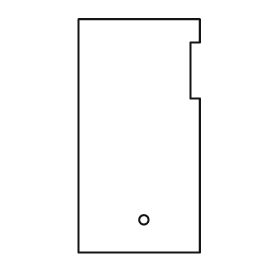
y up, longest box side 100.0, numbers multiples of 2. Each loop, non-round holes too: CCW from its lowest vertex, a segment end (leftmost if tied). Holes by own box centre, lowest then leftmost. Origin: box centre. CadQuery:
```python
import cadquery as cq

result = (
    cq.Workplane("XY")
    .moveTo(-26.0, -50.0)
    .lineTo(26.0, -50.0)
    .lineTo(26.0, 16.0)
    .lineTo(22.0, 16.0)
    .lineTo(22.0, 40.0)
    .lineTo(26.0, 40.0)
    .lineTo(26.0, 50.0)
    .lineTo(-26.0, 50.0)
    .close()
    .moveTo(2.0, -36.0)
    .circle(2.0)
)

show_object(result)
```